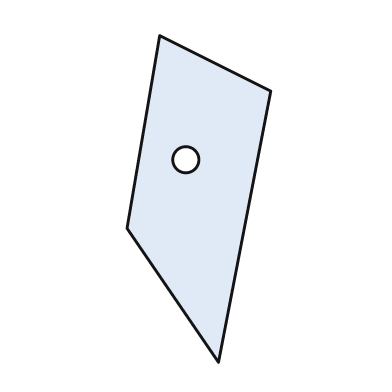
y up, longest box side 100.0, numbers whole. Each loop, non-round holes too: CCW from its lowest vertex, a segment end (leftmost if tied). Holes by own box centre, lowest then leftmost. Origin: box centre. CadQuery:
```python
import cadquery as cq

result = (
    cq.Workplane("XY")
    .moveTo(6.0, -50.0)
    .lineTo(22.0, 33.0)
    .lineTo(-12.0, 50.0)
    .lineTo(-22.0, -9.0)
    .close()
    .moveTo(-4.0, 12.0)
    .circle(4.0)
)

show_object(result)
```